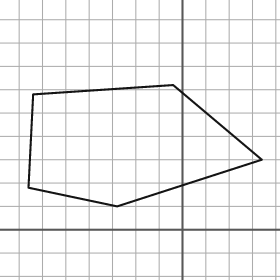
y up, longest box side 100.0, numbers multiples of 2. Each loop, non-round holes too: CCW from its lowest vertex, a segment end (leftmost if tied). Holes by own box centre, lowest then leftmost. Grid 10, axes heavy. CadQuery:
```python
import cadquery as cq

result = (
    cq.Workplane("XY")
    .moveTo(-28.0, 10.0)
    .lineTo(34.0, 30.0)
    .lineTo(-4.0, 62.0)
    .lineTo(-64.0, 58.0)
    .lineTo(-66.0, 18.0)
    .close()
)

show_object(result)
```